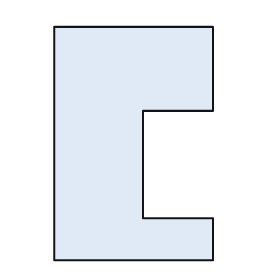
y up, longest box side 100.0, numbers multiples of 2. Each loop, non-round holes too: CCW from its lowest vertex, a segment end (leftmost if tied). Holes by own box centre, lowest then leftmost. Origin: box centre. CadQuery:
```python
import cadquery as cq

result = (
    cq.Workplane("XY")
    .moveTo(-34.0, -50.0)
    .lineTo(34.0, -50.0)
    .lineTo(34.0, -32.0)
    .lineTo(4.0, -32.0)
    .lineTo(4.0, 14.0)
    .lineTo(34.0, 14.0)
    .lineTo(34.0, 50.0)
    .lineTo(-34.0, 50.0)
    .close()
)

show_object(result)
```